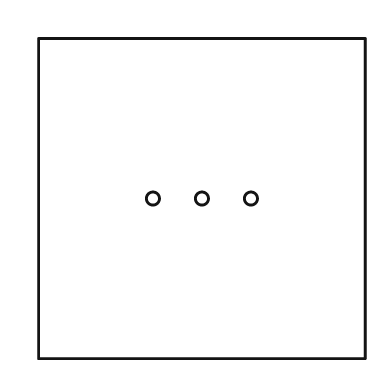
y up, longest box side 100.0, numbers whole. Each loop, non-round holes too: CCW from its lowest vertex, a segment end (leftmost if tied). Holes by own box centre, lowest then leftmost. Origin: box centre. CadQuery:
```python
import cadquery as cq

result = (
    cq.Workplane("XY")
    .moveTo(-50.0, -49.0)
    .lineTo(50.0, -49.0)
    .lineTo(50.0, 49.0)
    .lineTo(-50.0, 49.0)
    .close()
    .moveTo(-15.0, 0.0)
    .circle(2.0)
    .moveTo(0.0, 0.0)
    .circle(2.0)
    .moveTo(15.0, 0.0)
    .circle(2.0)
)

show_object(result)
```